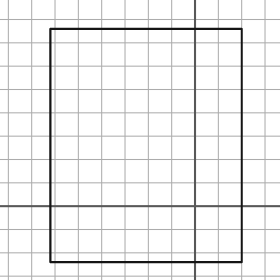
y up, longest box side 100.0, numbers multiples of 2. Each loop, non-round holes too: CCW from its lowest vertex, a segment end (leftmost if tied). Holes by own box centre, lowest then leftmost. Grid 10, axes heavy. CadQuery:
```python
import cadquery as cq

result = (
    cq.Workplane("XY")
    .moveTo(-62.0, -24.0)
    .lineTo(20.0, -24.0)
    .lineTo(20.0, 76.0)
    .lineTo(-62.0, 76.0)
    .close()
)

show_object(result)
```